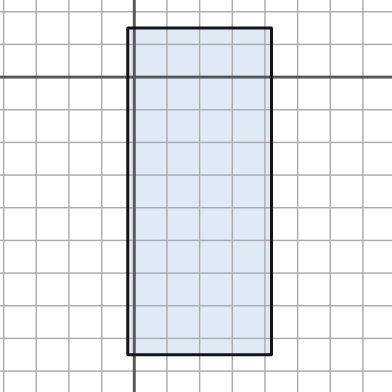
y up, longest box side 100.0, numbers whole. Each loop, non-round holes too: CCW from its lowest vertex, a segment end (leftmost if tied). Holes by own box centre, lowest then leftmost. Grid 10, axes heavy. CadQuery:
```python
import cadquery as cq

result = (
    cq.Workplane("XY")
    .moveTo(-2.0, -85.0)
    .lineTo(42.0, -85.0)
    .lineTo(42.0, 15.0)
    .lineTo(-2.0, 15.0)
    .close()
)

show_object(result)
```